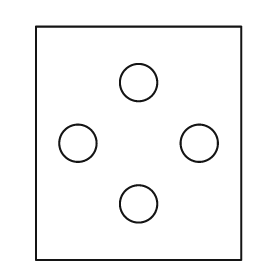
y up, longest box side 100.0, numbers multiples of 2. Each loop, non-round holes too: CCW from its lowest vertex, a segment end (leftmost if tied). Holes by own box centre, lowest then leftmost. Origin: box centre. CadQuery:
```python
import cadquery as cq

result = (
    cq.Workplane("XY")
    .moveTo(-44.0, -50.0)
    .lineTo(44.0, -50.0)
    .lineTo(44.0, 50.0)
    .lineTo(-44.0, 50.0)
    .close()
    .moveTo(0.0, -26.0)
    .circle(8.0)
    .moveTo(-26.0, 0.0)
    .circle(8.0)
    .moveTo(26.0, 0.0)
    .circle(8.0)
    .moveTo(0.0, 26.0)
    .circle(8.0)
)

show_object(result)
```